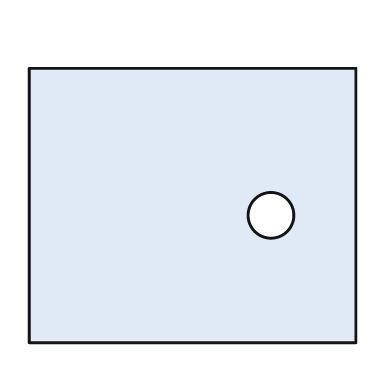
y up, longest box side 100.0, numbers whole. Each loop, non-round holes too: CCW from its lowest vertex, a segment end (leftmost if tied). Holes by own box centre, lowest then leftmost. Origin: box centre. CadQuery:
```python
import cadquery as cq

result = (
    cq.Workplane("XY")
    .moveTo(-50.0, -42.0)
    .lineTo(50.0, -42.0)
    .lineTo(50.0, 42.0)
    .lineTo(-50.0, 42.0)
    .close()
    .moveTo(24.0, -3.0)
    .circle(7.0)
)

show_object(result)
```